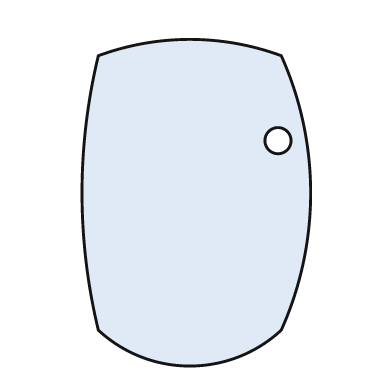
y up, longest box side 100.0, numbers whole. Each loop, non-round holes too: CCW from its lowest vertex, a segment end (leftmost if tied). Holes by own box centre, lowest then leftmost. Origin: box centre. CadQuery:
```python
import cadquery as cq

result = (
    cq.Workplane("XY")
    .moveTo(-30.0, -39.0)
    .threePointArc((-2.0, -50.0), (26.0, -39.0))
    .threePointArc((35.0, 3.0), (26.0, 45.0))
    .threePointArc((-2.0, 50.0), (-30.0, 45.0))
    .threePointArc((-35.0, 3.0), (-30.0, -39.0))
    .close()
    .moveTo(25.0, 19.0)
    .circle(4.0)
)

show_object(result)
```